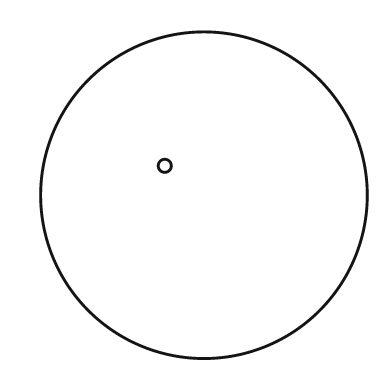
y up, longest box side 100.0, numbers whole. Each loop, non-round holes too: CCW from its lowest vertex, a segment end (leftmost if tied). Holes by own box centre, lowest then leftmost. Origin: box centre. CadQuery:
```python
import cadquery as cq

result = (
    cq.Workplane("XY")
    .moveTo(0.0, 0.0)
    .circle(50.0)
    .moveTo(-12.0, 9.0)
    .circle(2.0)
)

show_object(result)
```